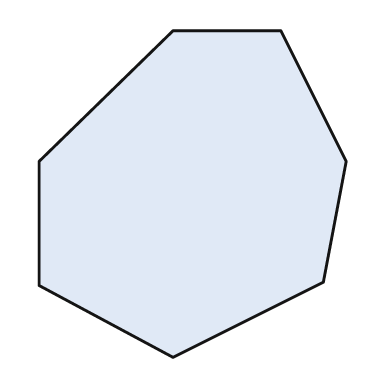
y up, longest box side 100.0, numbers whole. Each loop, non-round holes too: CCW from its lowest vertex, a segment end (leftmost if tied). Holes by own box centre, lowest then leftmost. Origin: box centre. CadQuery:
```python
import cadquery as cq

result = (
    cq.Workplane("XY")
    .moveTo(-6.0, -50.0)
    .lineTo(40.0, -27.0)
    .lineTo(47.0, 10.0)
    .lineTo(27.0, 50.0)
    .lineTo(-6.0, 50.0)
    .lineTo(-47.0, 10.0)
    .lineTo(-47.0, -28.0)
    .close()
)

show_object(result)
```